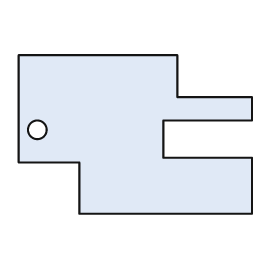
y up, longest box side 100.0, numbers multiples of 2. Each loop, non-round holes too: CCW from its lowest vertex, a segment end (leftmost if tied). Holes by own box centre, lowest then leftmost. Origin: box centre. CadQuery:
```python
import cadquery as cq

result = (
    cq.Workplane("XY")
    .moveTo(-24.0, -34.0)
    .lineTo(50.0, -34.0)
    .lineTo(50.0, -10.0)
    .lineTo(12.0, -10.0)
    .lineTo(12.0, 6.0)
    .lineTo(50.0, 6.0)
    .lineTo(50.0, 16.0)
    .lineTo(18.0, 16.0)
    .lineTo(18.0, 34.0)
    .lineTo(-50.0, 34.0)
    .lineTo(-50.0, -12.0)
    .lineTo(-24.0, -12.0)
    .close()
    .moveTo(-42.0, 2.0)
    .circle(4.0)
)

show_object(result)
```